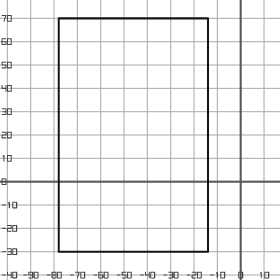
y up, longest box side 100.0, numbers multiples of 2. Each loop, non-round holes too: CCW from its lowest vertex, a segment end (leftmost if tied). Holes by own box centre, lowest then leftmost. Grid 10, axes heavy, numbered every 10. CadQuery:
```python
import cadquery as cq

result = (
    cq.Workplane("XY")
    .moveTo(-78.0, -30.0)
    .lineTo(-14.0, -30.0)
    .lineTo(-14.0, 70.0)
    .lineTo(-78.0, 70.0)
    .close()
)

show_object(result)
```